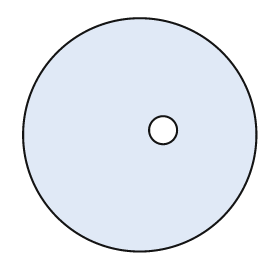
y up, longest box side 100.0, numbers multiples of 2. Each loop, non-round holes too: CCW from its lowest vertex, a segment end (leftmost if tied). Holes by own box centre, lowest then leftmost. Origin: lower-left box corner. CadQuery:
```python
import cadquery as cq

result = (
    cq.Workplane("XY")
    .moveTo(50.0, 50.0)
    .circle(50.0)
    .moveTo(60.0, 52.0)
    .circle(6.0)
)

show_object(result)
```